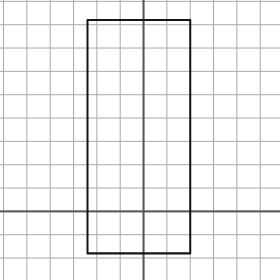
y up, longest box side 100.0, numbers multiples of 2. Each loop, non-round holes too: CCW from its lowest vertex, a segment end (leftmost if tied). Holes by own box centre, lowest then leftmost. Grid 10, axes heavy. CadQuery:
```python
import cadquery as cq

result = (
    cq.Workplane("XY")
    .moveTo(-24.0, -18.0)
    .lineTo(20.0, -18.0)
    .lineTo(20.0, 82.0)
    .lineTo(-24.0, 82.0)
    .close()
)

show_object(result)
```